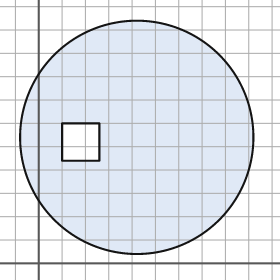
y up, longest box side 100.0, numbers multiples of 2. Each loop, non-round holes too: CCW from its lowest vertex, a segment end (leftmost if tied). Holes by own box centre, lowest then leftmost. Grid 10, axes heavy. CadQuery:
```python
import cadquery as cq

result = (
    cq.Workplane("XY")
    .moveTo(42.0, 54.0)
    .circle(50.0)
    .moveTo(10.0, 44.0)
    .lineTo(26.0, 44.0)
    .lineTo(26.0, 60.0)
    .lineTo(10.0, 60.0)
    .close()
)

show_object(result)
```